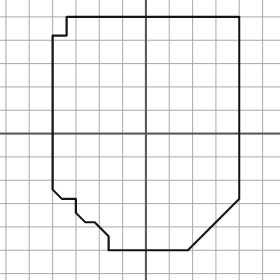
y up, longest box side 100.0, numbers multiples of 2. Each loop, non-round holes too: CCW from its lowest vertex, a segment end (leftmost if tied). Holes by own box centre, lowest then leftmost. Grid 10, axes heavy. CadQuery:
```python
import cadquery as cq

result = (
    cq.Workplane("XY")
    .moveTo(-16.0, -50.0)
    .lineTo(18.0, -50.0)
    .lineTo(40.0, -28.0)
    .lineTo(40.0, 50.0)
    .lineTo(-34.0, 50.0)
    .lineTo(-34.0, 42.0)
    .lineTo(-40.0, 42.0)
    .lineTo(-40.0, -24.0)
    .lineTo(-36.0, -28.0)
    .lineTo(-30.0, -28.0)
    .lineTo(-30.0, -34.0)
    .lineTo(-26.0, -38.0)
    .lineTo(-22.0, -38.0)
    .lineTo(-16.0, -44.0)
    .close()
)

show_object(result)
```